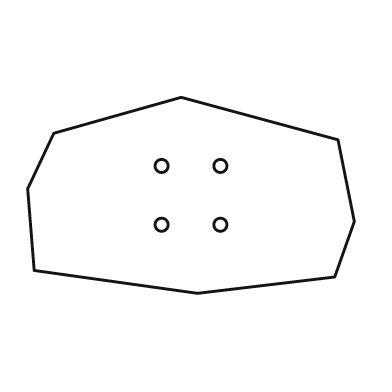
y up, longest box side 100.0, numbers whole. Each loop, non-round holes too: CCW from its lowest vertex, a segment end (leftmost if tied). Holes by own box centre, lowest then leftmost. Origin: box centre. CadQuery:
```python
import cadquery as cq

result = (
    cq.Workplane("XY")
    .moveTo(2.0, -30.0)
    .lineTo(44.0, -25.0)
    .lineTo(50.0, -8.0)
    .lineTo(45.0, 17.0)
    .lineTo(-3.0, 30.0)
    .lineTo(-42.0, 19.0)
    .lineTo(-50.0, 2.0)
    .lineTo(-48.0, -23.0)
    .close()
    .moveTo(-9.0, -9.0)
    .circle(2.0)
    .moveTo(9.0, -9.0)
    .circle(2.0)
    .moveTo(-9.0, 9.0)
    .circle(2.0)
    .moveTo(9.0, 9.0)
    .circle(2.0)
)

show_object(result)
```